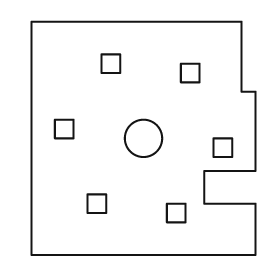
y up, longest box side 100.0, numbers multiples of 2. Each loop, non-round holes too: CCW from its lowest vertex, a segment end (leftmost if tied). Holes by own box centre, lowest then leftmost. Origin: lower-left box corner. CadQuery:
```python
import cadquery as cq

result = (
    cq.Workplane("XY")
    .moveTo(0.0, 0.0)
    .lineTo(96.0, 0.0)
    .lineTo(96.0, 22.0)
    .lineTo(74.0, 22.0)
    .lineTo(74.0, 36.0)
    .lineTo(96.0, 36.0)
    .lineTo(96.0, 70.0)
    .lineTo(90.0, 70.0)
    .lineTo(90.0, 100.0)
    .lineTo(0.0, 100.0)
    .close()
    .moveTo(58.0, 14.0)
    .lineTo(66.0, 14.0)
    .lineTo(66.0, 22.0)
    .lineTo(58.0, 22.0)
    .close()
    .moveTo(24.0, 18.0)
    .lineTo(32.0, 18.0)
    .lineTo(32.0, 26.0)
    .lineTo(24.0, 26.0)
    .close()
    .moveTo(78.0, 42.0)
    .lineTo(86.0, 42.0)
    .lineTo(86.0, 50.0)
    .lineTo(78.0, 50.0)
    .close()
    .moveTo(48.0, 50.0)
    .circle(8.0)
    .moveTo(10.0, 50.0)
    .lineTo(18.0, 50.0)
    .lineTo(18.0, 58.0)
    .lineTo(10.0, 58.0)
    .close()
    .moveTo(64.0, 74.0)
    .lineTo(72.0, 74.0)
    .lineTo(72.0, 82.0)
    .lineTo(64.0, 82.0)
    .close()
    .moveTo(30.0, 78.0)
    .lineTo(38.0, 78.0)
    .lineTo(38.0, 86.0)
    .lineTo(30.0, 86.0)
    .close()
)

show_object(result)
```